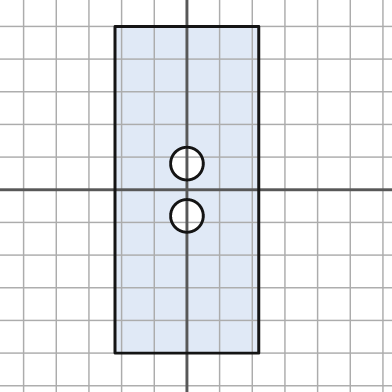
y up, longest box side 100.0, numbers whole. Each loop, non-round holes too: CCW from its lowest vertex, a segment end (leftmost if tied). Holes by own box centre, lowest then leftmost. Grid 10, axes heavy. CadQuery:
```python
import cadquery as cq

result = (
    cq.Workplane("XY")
    .moveTo(-22.0, -50.0)
    .lineTo(22.0, -50.0)
    .lineTo(22.0, 50.0)
    .lineTo(-22.0, 50.0)
    .close()
    .moveTo(0.0, -8.0)
    .circle(5.0)
    .moveTo(0.0, 8.0)
    .circle(5.0)
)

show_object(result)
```